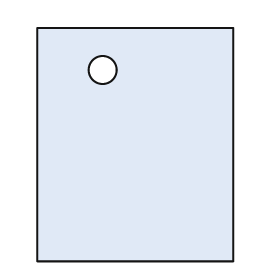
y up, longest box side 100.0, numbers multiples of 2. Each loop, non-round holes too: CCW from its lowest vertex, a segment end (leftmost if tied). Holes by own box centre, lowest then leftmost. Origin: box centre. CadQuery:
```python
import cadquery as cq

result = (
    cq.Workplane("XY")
    .moveTo(-42.0, -50.0)
    .lineTo(42.0, -50.0)
    .lineTo(42.0, 50.0)
    .lineTo(-42.0, 50.0)
    .close()
    .moveTo(-14.0, 32.0)
    .circle(6.0)
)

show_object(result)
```